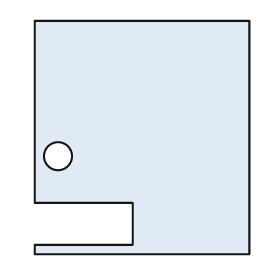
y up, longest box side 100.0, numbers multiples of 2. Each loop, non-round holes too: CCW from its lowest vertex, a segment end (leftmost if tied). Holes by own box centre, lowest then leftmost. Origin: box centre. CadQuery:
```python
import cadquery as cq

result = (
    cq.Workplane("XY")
    .moveTo(-46.0, -50.0)
    .lineTo(46.0, -50.0)
    .lineTo(46.0, 50.0)
    .lineTo(-46.0, 50.0)
    .lineTo(-46.0, -28.0)
    .lineTo(-4.0, -28.0)
    .lineTo(-4.0, -46.0)
    .lineTo(-46.0, -46.0)
    .close()
    .moveTo(-36.0, -8.0)
    .circle(6.0)
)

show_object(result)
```